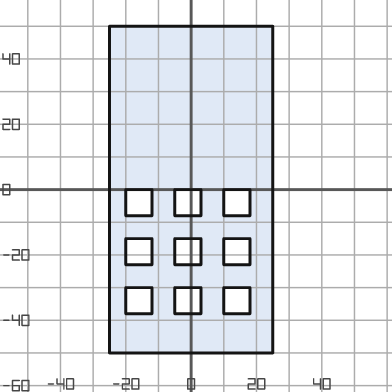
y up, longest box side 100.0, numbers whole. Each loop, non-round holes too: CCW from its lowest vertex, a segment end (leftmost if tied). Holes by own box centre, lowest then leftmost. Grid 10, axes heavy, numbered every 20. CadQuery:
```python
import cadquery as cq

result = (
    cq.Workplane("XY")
    .moveTo(-25.0, -50.0)
    .lineTo(25.0, -50.0)
    .lineTo(25.0, 50.0)
    .lineTo(-25.0, 50.0)
    .close()
    .moveTo(-20.0, -38.0)
    .lineTo(-12.0, -38.0)
    .lineTo(-12.0, -30.0)
    .lineTo(-20.0, -30.0)
    .close()
    .moveTo(-5.0, -38.0)
    .lineTo(3.0, -38.0)
    .lineTo(3.0, -30.0)
    .lineTo(-5.0, -30.0)
    .close()
    .moveTo(10.0, -38.0)
    .lineTo(18.0, -38.0)
    .lineTo(18.0, -30.0)
    .lineTo(10.0, -30.0)
    .close()
    .moveTo(-20.0, -23.0)
    .lineTo(-12.0, -23.0)
    .lineTo(-12.0, -15.0)
    .lineTo(-20.0, -15.0)
    .close()
    .moveTo(-5.0, -23.0)
    .lineTo(3.0, -23.0)
    .lineTo(3.0, -15.0)
    .lineTo(-5.0, -15.0)
    .close()
    .moveTo(10.0, -23.0)
    .lineTo(18.0, -23.0)
    .lineTo(18.0, -15.0)
    .lineTo(10.0, -15.0)
    .close()
    .moveTo(-20.0, -8.0)
    .lineTo(-12.0, -8.0)
    .lineTo(-12.0, 0.0)
    .lineTo(-20.0, 0.0)
    .close()
    .moveTo(-5.0, -8.0)
    .lineTo(3.0, -8.0)
    .lineTo(3.0, 0.0)
    .lineTo(-5.0, 0.0)
    .close()
    .moveTo(10.0, -8.0)
    .lineTo(18.0, -8.0)
    .lineTo(18.0, 0.0)
    .lineTo(10.0, 0.0)
    .close()
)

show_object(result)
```